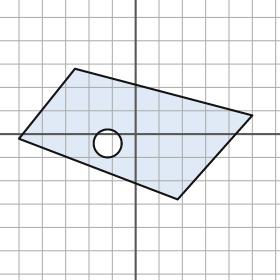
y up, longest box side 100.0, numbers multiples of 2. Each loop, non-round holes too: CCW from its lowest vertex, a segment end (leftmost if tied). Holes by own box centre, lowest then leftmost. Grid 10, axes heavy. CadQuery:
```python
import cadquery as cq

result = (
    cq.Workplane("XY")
    .moveTo(18.0, -28.0)
    .lineTo(50.0, 8.0)
    .lineTo(-26.0, 28.0)
    .lineTo(-50.0, -2.0)
    .close()
    .moveTo(-12.0, -4.0)
    .circle(6.0)
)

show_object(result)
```